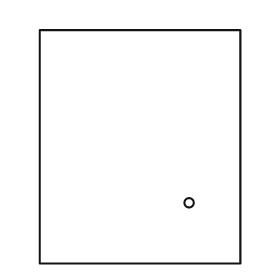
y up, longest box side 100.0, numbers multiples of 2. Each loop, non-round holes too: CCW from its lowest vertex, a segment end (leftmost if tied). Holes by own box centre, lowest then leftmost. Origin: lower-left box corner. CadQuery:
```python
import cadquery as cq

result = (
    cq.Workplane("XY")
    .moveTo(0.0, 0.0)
    .lineTo(86.0, 0.0)
    .lineTo(86.0, 100.0)
    .lineTo(0.0, 100.0)
    .close()
    .moveTo(64.0, 26.0)
    .circle(2.0)
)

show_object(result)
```